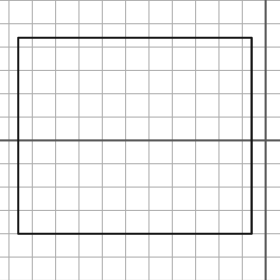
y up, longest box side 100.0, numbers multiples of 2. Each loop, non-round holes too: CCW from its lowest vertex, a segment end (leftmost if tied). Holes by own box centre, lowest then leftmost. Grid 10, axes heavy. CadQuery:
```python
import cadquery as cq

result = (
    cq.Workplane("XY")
    .moveTo(-106.0, -40.0)
    .lineTo(-6.0, -40.0)
    .lineTo(-6.0, 44.0)
    .lineTo(-106.0, 44.0)
    .close()
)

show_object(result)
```